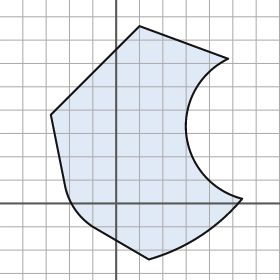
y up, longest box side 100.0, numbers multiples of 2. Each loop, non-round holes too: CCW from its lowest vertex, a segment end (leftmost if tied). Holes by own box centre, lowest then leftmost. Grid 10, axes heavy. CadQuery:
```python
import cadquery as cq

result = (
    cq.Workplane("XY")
    .moveTo(14.0, -24.0)
    .threePointArc((36.0, -14.0), (54.0, 2.0))
    .threePointArc((30.0, 30.0), (48.0, 62.0))
    .lineTo(10.0, 76.0)
    .lineTo(-28.0, 38.0)
    .lineTo(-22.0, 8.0)
    .threePointArc((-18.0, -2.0), (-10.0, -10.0))
    .close()
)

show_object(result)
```